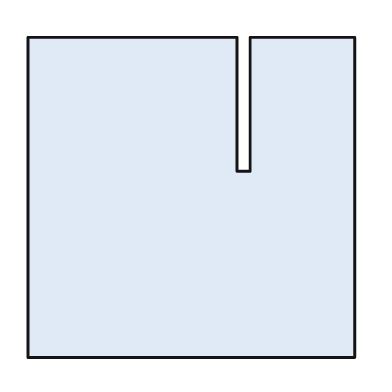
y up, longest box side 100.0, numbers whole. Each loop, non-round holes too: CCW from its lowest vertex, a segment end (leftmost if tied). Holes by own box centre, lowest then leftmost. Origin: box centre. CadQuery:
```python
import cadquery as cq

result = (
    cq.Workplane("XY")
    .moveTo(-50.0, -49.0)
    .lineTo(50.0, -49.0)
    .lineTo(50.0, 49.0)
    .lineTo(18.0, 49.0)
    .lineTo(18.0, 8.0)
    .lineTo(14.0, 8.0)
    .lineTo(14.0, 49.0)
    .lineTo(-50.0, 49.0)
    .close()
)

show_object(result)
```